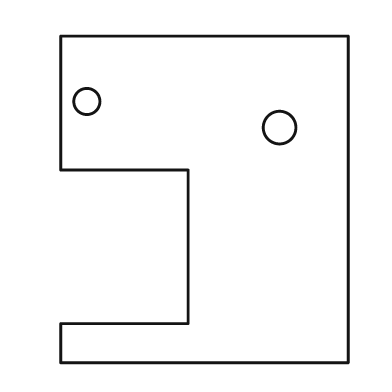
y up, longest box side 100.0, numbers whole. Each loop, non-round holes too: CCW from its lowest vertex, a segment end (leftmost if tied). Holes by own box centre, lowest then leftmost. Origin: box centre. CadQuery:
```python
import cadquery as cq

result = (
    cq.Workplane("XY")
    .moveTo(-44.0, -50.0)
    .lineTo(44.0, -50.0)
    .lineTo(44.0, 50.0)
    .lineTo(-44.0, 50.0)
    .lineTo(-44.0, 9.0)
    .lineTo(-5.0, 9.0)
    .lineTo(-5.0, -38.0)
    .lineTo(-44.0, -38.0)
    .close()
    .moveTo(23.0, 22.0)
    .circle(5.0)
    .moveTo(-36.0, 30.0)
    .circle(4.0)
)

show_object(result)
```